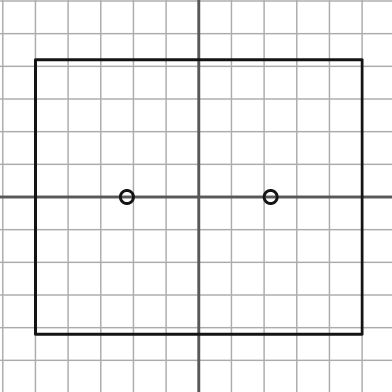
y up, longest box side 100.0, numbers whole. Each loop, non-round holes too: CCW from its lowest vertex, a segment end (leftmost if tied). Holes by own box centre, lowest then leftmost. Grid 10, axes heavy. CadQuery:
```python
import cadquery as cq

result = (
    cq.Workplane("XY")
    .moveTo(-50.0, -42.0)
    .lineTo(50.0, -42.0)
    .lineTo(50.0, 42.0)
    .lineTo(-50.0, 42.0)
    .close()
    .moveTo(-22.0, 0.0)
    .circle(2.0)
    .moveTo(22.0, 0.0)
    .circle(2.0)
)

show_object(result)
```